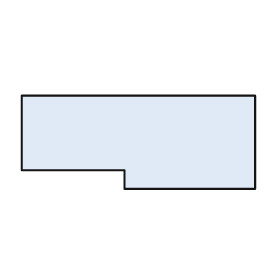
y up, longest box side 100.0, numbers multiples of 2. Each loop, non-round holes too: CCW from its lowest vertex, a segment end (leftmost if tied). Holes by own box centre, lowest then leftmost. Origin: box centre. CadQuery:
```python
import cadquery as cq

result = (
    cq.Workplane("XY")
    .moveTo(-6.0, -20.0)
    .lineTo(50.0, -20.0)
    .lineTo(50.0, 20.0)
    .lineTo(-50.0, 20.0)
    .lineTo(-50.0, -12.0)
    .lineTo(-6.0, -12.0)
    .close()
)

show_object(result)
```